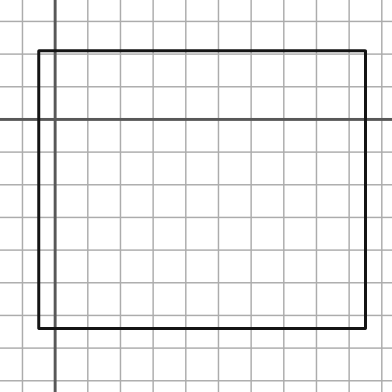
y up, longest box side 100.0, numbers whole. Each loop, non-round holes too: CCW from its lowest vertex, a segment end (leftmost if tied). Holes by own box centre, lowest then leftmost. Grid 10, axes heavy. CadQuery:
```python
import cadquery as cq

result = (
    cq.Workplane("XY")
    .moveTo(-5.0, -64.0)
    .lineTo(95.0, -64.0)
    .lineTo(95.0, 21.0)
    .lineTo(-5.0, 21.0)
    .close()
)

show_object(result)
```